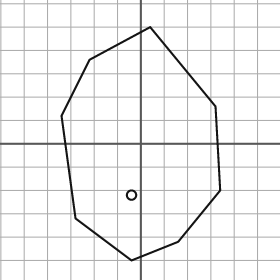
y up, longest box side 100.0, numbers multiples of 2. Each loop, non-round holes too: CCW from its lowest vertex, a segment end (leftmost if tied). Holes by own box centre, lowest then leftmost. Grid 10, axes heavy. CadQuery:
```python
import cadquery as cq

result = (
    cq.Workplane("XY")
    .moveTo(-4.0, -50.0)
    .lineTo(16.0, -42.0)
    .lineTo(34.0, -20.0)
    .lineTo(32.0, 16.0)
    .lineTo(4.0, 50.0)
    .lineTo(-22.0, 36.0)
    .lineTo(-34.0, 12.0)
    .lineTo(-28.0, -32.0)
    .close()
    .moveTo(-4.0, -22.0)
    .circle(2.0)
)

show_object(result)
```